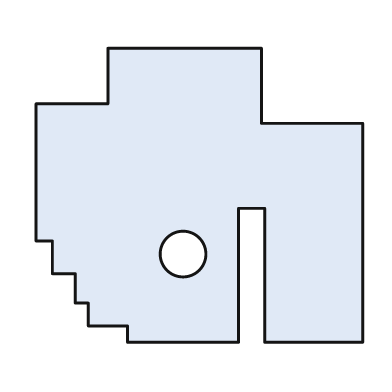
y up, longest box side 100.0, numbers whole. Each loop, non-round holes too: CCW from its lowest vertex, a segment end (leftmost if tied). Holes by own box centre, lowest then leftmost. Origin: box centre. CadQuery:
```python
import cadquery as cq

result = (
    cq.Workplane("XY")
    .moveTo(-22.0, -45.0)
    .lineTo(12.0, -45.0)
    .lineTo(12.0, -4.0)
    .lineTo(20.0, -4.0)
    .lineTo(20.0, -45.0)
    .lineTo(50.0, -45.0)
    .lineTo(50.0, 22.0)
    .lineTo(19.0, 22.0)
    .lineTo(19.0, 45.0)
    .lineTo(-28.0, 45.0)
    .lineTo(-28.0, 28.0)
    .lineTo(-50.0, 28.0)
    .lineTo(-50.0, -14.0)
    .lineTo(-45.0, -14.0)
    .lineTo(-45.0, -24.0)
    .lineTo(-38.0, -24.0)
    .lineTo(-38.0, -33.0)
    .lineTo(-34.0, -33.0)
    .lineTo(-34.0, -40.0)
    .lineTo(-22.0, -40.0)
    .close()
    .moveTo(-5.0, -18.0)
    .circle(7.0)
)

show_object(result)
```